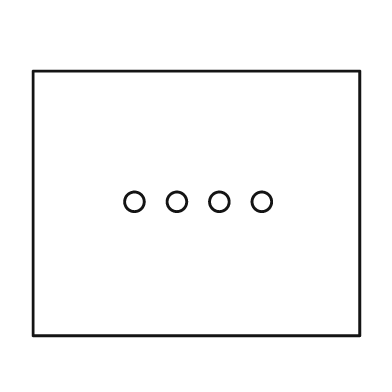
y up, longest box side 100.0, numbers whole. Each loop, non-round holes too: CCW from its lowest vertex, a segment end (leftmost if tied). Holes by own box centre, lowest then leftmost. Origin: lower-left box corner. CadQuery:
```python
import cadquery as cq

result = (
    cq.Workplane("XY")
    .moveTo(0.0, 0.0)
    .lineTo(100.0, 0.0)
    .lineTo(100.0, 81.0)
    .lineTo(0.0, 81.0)
    .close()
    .moveTo(31.0, 41.0)
    .circle(3.0)
    .moveTo(44.0, 41.0)
    .circle(3.0)
    .moveTo(57.0, 41.0)
    .circle(3.0)
    .moveTo(70.0, 41.0)
    .circle(3.0)
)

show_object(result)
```